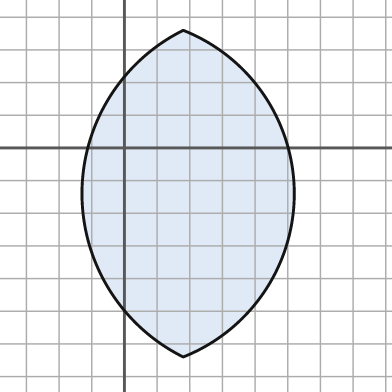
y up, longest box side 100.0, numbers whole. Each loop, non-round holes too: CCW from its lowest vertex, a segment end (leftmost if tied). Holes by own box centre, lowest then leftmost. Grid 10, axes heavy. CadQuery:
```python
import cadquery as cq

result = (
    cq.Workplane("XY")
    .moveTo(18.0, -64.0)
    .threePointArc((52.0, -14.0), (18.0, 36.0))
    .threePointArc((-13.0, -14.0), (18.0, -64.0))
    .close()
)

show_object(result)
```